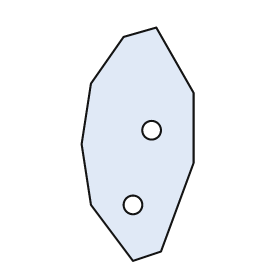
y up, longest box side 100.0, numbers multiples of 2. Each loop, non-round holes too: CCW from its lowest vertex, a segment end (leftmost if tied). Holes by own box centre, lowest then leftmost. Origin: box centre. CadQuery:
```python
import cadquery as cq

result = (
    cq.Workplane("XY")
    .moveTo(-2.0, -50.0)
    .lineTo(10.0, -46.0)
    .lineTo(24.0, -8.0)
    .lineTo(24.0, 22.0)
    .lineTo(8.0, 50.0)
    .lineTo(-6.0, 46.0)
    .lineTo(-20.0, 26.0)
    .lineTo(-24.0, 0.0)
    .lineTo(-20.0, -26.0)
    .close()
    .moveTo(-2.0, -26.0)
    .circle(4.0)
    .moveTo(6.0, 6.0)
    .circle(4.0)
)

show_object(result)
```